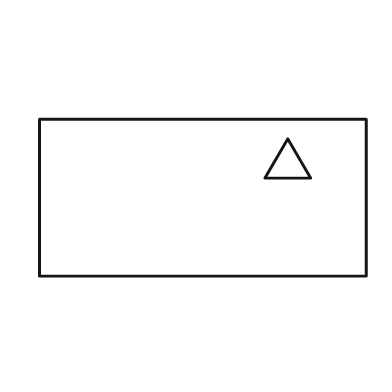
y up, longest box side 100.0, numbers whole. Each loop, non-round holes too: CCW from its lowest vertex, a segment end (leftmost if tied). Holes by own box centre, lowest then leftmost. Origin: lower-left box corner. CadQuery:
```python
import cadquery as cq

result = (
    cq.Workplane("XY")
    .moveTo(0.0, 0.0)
    .lineTo(100.0, 0.0)
    .lineTo(100.0, 48.0)
    .lineTo(0.0, 48.0)
    .close()
    .moveTo(69.0, 30.0)
    .lineTo(83.0, 30.0)
    .lineTo(76.0, 42.0)
    .close()
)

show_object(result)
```